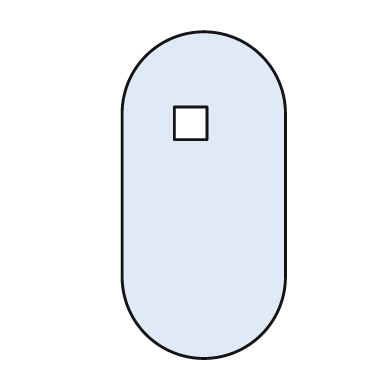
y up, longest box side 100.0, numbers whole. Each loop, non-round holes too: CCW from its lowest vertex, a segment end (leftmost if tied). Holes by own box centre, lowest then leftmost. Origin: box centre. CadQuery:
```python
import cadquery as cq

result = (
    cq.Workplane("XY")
    .moveTo(-25.0, -25.0)
    .threePointArc((0.0, -50.0), (25.0, -25.0))
    .lineTo(25.0, 25.0)
    .threePointArc((0.0, 50.0), (-25.0, 25.0))
    .close()
    .moveTo(-9.0, 17.0)
    .lineTo(1.0, 17.0)
    .lineTo(1.0, 27.0)
    .lineTo(-9.0, 27.0)
    .close()
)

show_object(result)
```